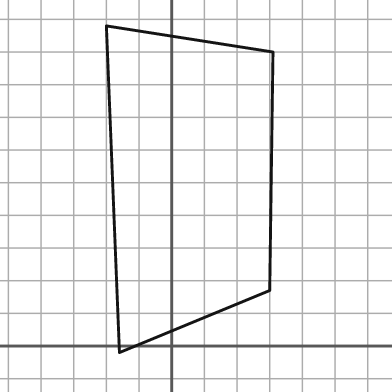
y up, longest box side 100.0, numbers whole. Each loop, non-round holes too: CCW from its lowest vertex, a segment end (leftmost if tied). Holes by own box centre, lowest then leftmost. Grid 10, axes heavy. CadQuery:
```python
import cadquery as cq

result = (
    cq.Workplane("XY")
    .moveTo(-16.0, -2.0)
    .lineTo(30.0, 17.0)
    .lineTo(31.0, 90.0)
    .lineTo(-20.0, 98.0)
    .close()
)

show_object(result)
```